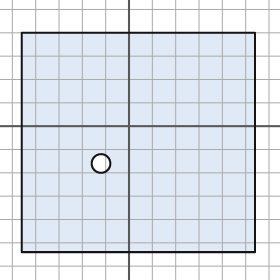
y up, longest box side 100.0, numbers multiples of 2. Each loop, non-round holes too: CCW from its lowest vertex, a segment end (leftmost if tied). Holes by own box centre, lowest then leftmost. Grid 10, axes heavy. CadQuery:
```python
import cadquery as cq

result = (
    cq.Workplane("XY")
    .moveTo(-46.0, -54.0)
    .lineTo(54.0, -54.0)
    .lineTo(54.0, 40.0)
    .lineTo(-46.0, 40.0)
    .close()
    .moveTo(-12.0, -16.0)
    .circle(4.0)
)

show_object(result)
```